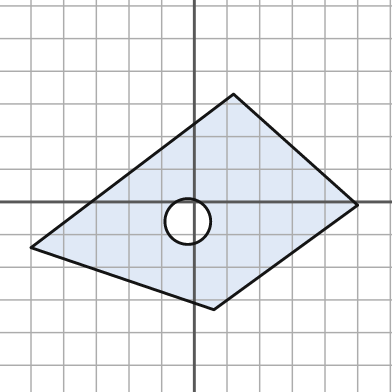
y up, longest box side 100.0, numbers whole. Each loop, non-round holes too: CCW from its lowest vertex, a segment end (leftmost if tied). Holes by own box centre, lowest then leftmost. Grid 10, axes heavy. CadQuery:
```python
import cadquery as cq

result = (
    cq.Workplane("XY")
    .moveTo(6.0, -33.0)
    .lineTo(50.0, -1.0)
    .lineTo(12.0, 33.0)
    .lineTo(-50.0, -14.0)
    .close()
    .moveTo(-2.0, -6.0)
    .circle(7.0)
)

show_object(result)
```